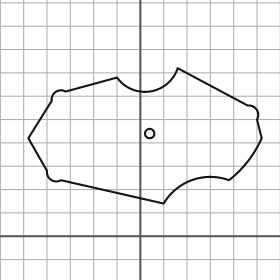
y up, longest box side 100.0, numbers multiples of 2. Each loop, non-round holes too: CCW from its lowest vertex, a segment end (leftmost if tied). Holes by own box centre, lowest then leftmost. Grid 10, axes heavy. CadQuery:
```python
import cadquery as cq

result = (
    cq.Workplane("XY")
    .moveTo(10.0, 14.0)
    .threePointArc((22.0, 24.0), (38.0, 24.0))
    .threePointArc((46.0, 32.0), (52.0, 42.0))
    .lineTo(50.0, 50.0)
    .threePointArc((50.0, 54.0), (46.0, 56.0))
    .lineTo(16.0, 72.0)
    .threePointArc((4.0, 62.0), (-10.0, 68.0))
    .lineTo(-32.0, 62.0)
    .threePointArc((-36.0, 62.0), (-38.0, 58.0))
    .lineTo(-48.0, 42.0)
    .lineTo(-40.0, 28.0)
    .threePointArc((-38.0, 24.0), (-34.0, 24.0))
    .close()
    .moveTo(4.0, 44.0)
    .circle(2.0)
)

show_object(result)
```